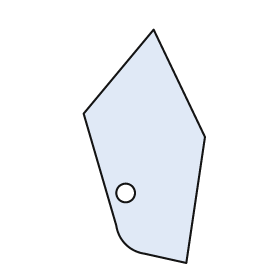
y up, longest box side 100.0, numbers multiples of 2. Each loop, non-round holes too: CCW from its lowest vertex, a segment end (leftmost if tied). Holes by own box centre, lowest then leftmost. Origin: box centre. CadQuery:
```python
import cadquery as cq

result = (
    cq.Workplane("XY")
    .moveTo(18.0, -50.0)
    .lineTo(26.0, 4.0)
    .lineTo(4.0, 50.0)
    .lineTo(-26.0, 14.0)
    .lineTo(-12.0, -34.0)
    .threePointArc((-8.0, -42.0), (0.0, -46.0))
    .close()
    .moveTo(-8.0, -20.0)
    .circle(4.0)
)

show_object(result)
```